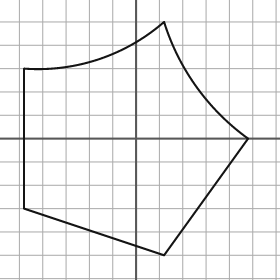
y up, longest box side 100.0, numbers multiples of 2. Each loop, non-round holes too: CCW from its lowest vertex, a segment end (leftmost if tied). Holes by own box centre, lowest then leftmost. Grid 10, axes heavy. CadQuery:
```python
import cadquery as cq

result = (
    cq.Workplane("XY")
    .moveTo(12.0, -50.0)
    .lineTo(48.0, 0.0)
    .threePointArc((26.0, 22.0), (12.0, 50.0))
    .threePointArc((-16.0, 34.0), (-48.0, 30.0))
    .lineTo(-48.0, -30.0)
    .close()
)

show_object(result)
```